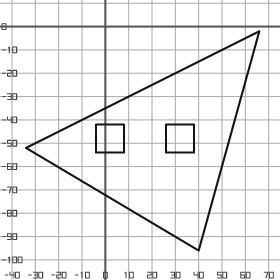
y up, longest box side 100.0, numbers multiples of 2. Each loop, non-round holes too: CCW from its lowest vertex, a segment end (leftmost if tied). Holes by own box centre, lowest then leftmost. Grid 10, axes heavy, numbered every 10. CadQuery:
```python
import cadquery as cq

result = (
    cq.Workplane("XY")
    .moveTo(40.0, -96.0)
    .lineTo(66.0, -2.0)
    .lineTo(-34.0, -52.0)
    .close()
    .moveTo(-4.0, -54.0)
    .lineTo(8.0, -54.0)
    .lineTo(8.0, -42.0)
    .lineTo(-4.0, -42.0)
    .close()
    .moveTo(26.0, -54.0)
    .lineTo(38.0, -54.0)
    .lineTo(38.0, -42.0)
    .lineTo(26.0, -42.0)
    .close()
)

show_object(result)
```